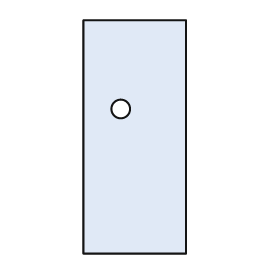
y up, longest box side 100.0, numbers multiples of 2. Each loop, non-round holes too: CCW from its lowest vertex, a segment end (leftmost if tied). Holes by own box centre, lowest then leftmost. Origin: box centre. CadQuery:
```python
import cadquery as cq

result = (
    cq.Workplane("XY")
    .moveTo(-22.0, -50.0)
    .lineTo(22.0, -50.0)
    .lineTo(22.0, 50.0)
    .lineTo(-22.0, 50.0)
    .close()
    .moveTo(-6.0, 12.0)
    .circle(4.0)
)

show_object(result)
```